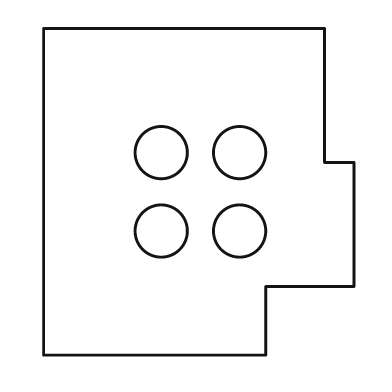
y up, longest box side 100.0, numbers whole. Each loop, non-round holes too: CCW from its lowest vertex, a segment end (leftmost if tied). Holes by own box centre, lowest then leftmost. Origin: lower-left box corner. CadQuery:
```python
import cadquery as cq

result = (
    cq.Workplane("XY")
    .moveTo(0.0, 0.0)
    .lineTo(68.0, 0.0)
    .lineTo(68.0, 21.0)
    .lineTo(95.0, 21.0)
    .lineTo(95.0, 59.0)
    .lineTo(86.0, 59.0)
    .lineTo(86.0, 100.0)
    .lineTo(0.0, 100.0)
    .close()
    .moveTo(36.0, 38.0)
    .circle(8.0)
    .moveTo(60.0, 38.0)
    .circle(8.0)
    .moveTo(36.0, 62.0)
    .circle(8.0)
    .moveTo(60.0, 62.0)
    .circle(8.0)
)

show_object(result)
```